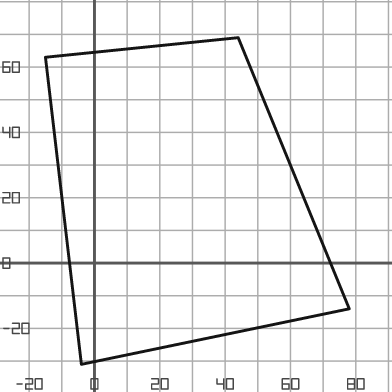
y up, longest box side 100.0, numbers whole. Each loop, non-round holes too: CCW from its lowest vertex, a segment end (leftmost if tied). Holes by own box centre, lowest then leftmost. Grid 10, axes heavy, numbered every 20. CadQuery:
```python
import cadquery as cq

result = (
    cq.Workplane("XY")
    .moveTo(-4.0, -31.0)
    .lineTo(78.0, -14.0)
    .lineTo(44.0, 69.0)
    .lineTo(-15.0, 63.0)
    .close()
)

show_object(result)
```